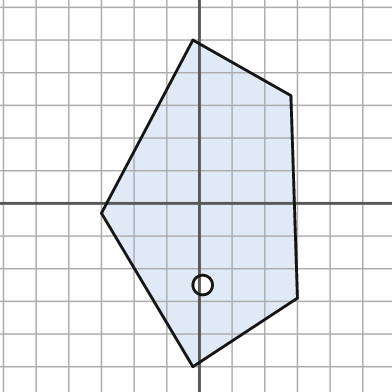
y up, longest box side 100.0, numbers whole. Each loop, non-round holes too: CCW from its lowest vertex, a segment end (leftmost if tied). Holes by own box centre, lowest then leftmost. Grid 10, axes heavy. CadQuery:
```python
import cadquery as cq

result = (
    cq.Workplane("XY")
    .moveTo(-2.0, -50.0)
    .lineTo(30.0, -29.0)
    .lineTo(28.0, 33.0)
    .lineTo(-2.0, 50.0)
    .lineTo(-30.0, -3.0)
    .close()
    .moveTo(1.0, -25.0)
    .circle(3.0)
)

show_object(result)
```